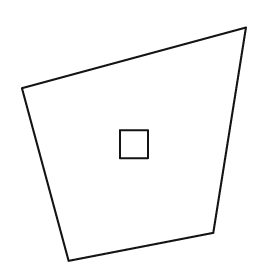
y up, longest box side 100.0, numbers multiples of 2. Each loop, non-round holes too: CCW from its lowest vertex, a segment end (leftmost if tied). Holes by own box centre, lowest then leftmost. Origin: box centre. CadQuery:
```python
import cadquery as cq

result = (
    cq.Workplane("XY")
    .moveTo(-28.0, -50.0)
    .lineTo(34.0, -38.0)
    .lineTo(48.0, 50.0)
    .lineTo(-48.0, 24.0)
    .close()
    .moveTo(-6.0, -6.0)
    .lineTo(6.0, -6.0)
    .lineTo(6.0, 6.0)
    .lineTo(-6.0, 6.0)
    .close()
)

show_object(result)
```